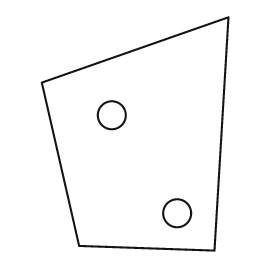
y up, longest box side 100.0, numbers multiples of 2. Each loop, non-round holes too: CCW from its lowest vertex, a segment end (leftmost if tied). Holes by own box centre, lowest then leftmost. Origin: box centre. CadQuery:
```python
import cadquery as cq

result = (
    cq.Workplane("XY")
    .moveTo(34.0, -50.0)
    .lineTo(40.0, 50.0)
    .lineTo(-40.0, 22.0)
    .lineTo(-24.0, -48.0)
    .close()
    .moveTo(18.0, -34.0)
    .circle(6.0)
    .moveTo(-10.0, 8.0)
    .circle(6.0)
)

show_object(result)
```